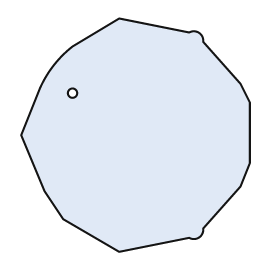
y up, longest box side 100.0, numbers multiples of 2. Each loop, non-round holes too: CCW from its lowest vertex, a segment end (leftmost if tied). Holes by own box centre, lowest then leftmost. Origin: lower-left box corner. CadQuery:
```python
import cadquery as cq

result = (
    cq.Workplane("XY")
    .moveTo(42.0, 0.0)
    .lineTo(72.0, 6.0)
    .threePointArc((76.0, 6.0), (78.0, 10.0))
    .lineTo(94.0, 28.0)
    .lineTo(98.0, 38.0)
    .lineTo(98.0, 64.0)
    .lineTo(94.0, 72.0)
    .lineTo(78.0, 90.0)
    .threePointArc((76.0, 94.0), (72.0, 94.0))
    .lineTo(42.0, 100.0)
    .lineTo(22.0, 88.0)
    .threePointArc((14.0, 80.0), (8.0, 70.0))
    .lineTo(0.0, 50.0)
    .lineTo(10.0, 26.0)
    .lineTo(18.0, 14.0)
    .close()
    .moveTo(22.0, 68.0)
    .circle(2.0)
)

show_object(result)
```